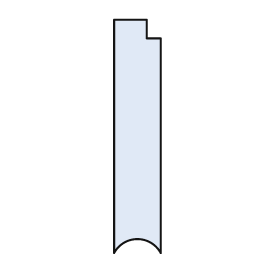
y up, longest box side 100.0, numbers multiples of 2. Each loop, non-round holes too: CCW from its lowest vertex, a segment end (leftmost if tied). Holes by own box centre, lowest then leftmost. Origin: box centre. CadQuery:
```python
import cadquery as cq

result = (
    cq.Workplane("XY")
    .moveTo(-10.0, -50.0)
    .threePointArc((0.0, -44.0), (10.0, -50.0))
    .lineTo(10.0, 42.0)
    .lineTo(4.0, 42.0)
    .lineTo(4.0, 50.0)
    .lineTo(-10.0, 50.0)
    .close()
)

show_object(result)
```